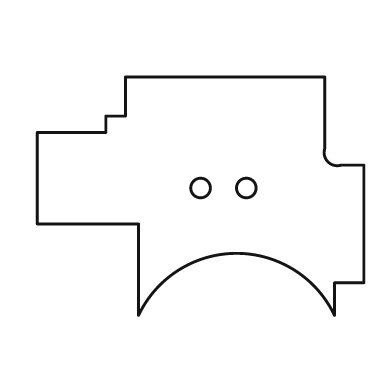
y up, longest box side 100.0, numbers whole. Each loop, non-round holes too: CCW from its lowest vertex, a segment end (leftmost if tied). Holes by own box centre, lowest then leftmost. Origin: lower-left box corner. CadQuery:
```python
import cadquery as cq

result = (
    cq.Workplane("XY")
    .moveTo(31.0, 0.0)
    .threePointArc((61.0, 19.0), (91.0, 0.0))
    .lineTo(91.0, 10.0)
    .lineTo(100.0, 10.0)
    .lineTo(100.0, 46.0)
    .lineTo(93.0, 46.0)
    .threePointArc((89.0, 47.0), (88.0, 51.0))
    .lineTo(88.0, 73.0)
    .lineTo(27.0, 73.0)
    .lineTo(27.0, 61.0)
    .lineTo(21.0, 61.0)
    .lineTo(21.0, 56.0)
    .lineTo(0.0, 56.0)
    .lineTo(0.0, 28.0)
    .lineTo(31.0, 28.0)
    .close()
    .moveTo(50.0, 39.0)
    .circle(3.0)
    .moveTo(64.0, 39.0)
    .circle(3.0)
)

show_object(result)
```